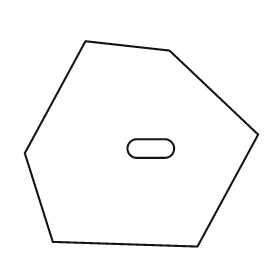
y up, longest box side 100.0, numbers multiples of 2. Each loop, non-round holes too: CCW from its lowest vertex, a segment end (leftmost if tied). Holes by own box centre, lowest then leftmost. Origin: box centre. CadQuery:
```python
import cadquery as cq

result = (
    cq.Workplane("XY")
    .moveTo(24.0, -44.0)
    .lineTo(50.0, 4.0)
    .lineTo(12.0, 40.0)
    .lineTo(-24.0, 44.0)
    .lineTo(-50.0, -4.0)
    .lineTo(-38.0, -42.0)
    .close()
    .moveTo(-2.0, -6.0)
    .lineTo(10.0, -6.0)
    .threePointArc((14.0, -2.0), (10.0, 2.0))
    .lineTo(-2.0, 2.0)
    .threePointArc((-6.0, -2.0), (-2.0, -6.0))
    .close()
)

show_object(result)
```